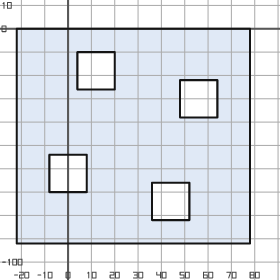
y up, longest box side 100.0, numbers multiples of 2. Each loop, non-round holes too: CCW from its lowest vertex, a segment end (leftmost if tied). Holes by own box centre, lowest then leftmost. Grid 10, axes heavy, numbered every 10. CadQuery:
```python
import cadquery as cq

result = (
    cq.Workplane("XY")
    .moveTo(-22.0, -92.0)
    .lineTo(78.0, -92.0)
    .lineTo(78.0, 0.0)
    .lineTo(-22.0, 0.0)
    .close()
    .moveTo(36.0, -82.0)
    .lineTo(52.0, -82.0)
    .lineTo(52.0, -66.0)
    .lineTo(36.0, -66.0)
    .close()
    .moveTo(-8.0, -70.0)
    .lineTo(8.0, -70.0)
    .lineTo(8.0, -54.0)
    .lineTo(-8.0, -54.0)
    .close()
    .moveTo(48.0, -38.0)
    .lineTo(64.0, -38.0)
    .lineTo(64.0, -22.0)
    .lineTo(48.0, -22.0)
    .close()
    .moveTo(4.0, -26.0)
    .lineTo(20.0, -26.0)
    .lineTo(20.0, -10.0)
    .lineTo(4.0, -10.0)
    .close()
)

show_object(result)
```